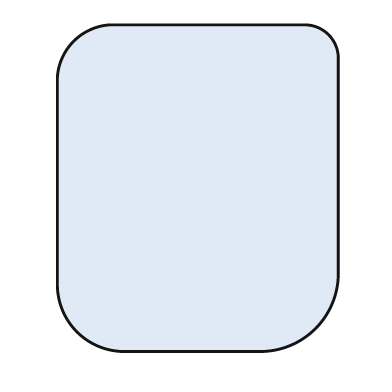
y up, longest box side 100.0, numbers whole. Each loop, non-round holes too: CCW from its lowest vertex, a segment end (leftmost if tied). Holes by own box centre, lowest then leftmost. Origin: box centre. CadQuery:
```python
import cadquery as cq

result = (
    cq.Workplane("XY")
    .moveTo(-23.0, -50.0)
    .lineTo(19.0, -50.0)
    .threePointArc((36.0, -43.0), (43.0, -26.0))
    .lineTo(43.0, 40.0)
    .threePointArc((40.0, 47.0), (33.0, 50.0))
    .lineTo(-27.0, 50.0)
    .threePointArc((-38.0, 45.0), (-43.0, 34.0))
    .lineTo(-43.0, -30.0)
    .threePointArc((-37.0, -44.0), (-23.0, -50.0))
    .close()
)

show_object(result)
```